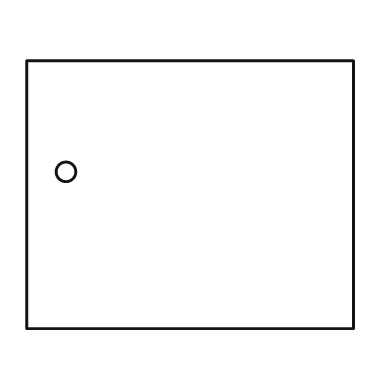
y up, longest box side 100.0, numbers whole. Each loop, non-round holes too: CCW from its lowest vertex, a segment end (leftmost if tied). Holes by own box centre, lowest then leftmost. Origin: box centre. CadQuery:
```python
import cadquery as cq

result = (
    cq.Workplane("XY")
    .moveTo(-50.0, -41.0)
    .lineTo(50.0, -41.0)
    .lineTo(50.0, 41.0)
    .lineTo(-50.0, 41.0)
    .close()
    .moveTo(-38.0, 7.0)
    .circle(3.0)
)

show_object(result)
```